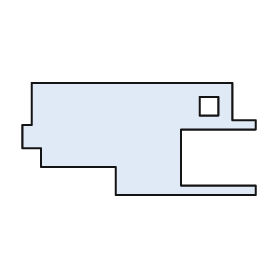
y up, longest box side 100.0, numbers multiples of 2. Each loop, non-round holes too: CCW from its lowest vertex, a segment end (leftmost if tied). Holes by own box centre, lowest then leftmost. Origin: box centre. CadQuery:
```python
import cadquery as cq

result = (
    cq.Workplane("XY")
    .moveTo(-10.0, -24.0)
    .lineTo(50.0, -24.0)
    .lineTo(50.0, -20.0)
    .lineTo(18.0, -20.0)
    .lineTo(18.0, 4.0)
    .lineTo(50.0, 4.0)
    .lineTo(50.0, 8.0)
    .lineTo(40.0, 8.0)
    .lineTo(40.0, 24.0)
    .lineTo(-46.0, 24.0)
    .lineTo(-46.0, 6.0)
    .lineTo(-50.0, 6.0)
    .lineTo(-50.0, -4.0)
    .lineTo(-42.0, -4.0)
    .lineTo(-42.0, -12.0)
    .lineTo(-10.0, -12.0)
    .close()
    .moveTo(26.0, 10.0)
    .lineTo(34.0, 10.0)
    .lineTo(34.0, 18.0)
    .lineTo(26.0, 18.0)
    .close()
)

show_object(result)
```